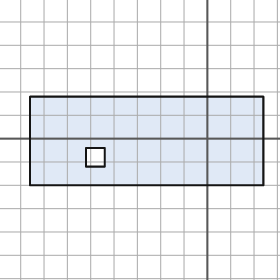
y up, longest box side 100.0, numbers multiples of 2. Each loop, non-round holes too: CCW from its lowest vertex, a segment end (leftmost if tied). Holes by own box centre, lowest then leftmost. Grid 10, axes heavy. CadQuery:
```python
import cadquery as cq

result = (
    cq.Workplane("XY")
    .moveTo(-76.0, -20.0)
    .lineTo(24.0, -20.0)
    .lineTo(24.0, 18.0)
    .lineTo(-76.0, 18.0)
    .close()
    .moveTo(-52.0, -12.0)
    .lineTo(-44.0, -12.0)
    .lineTo(-44.0, -4.0)
    .lineTo(-52.0, -4.0)
    .close()
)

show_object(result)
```